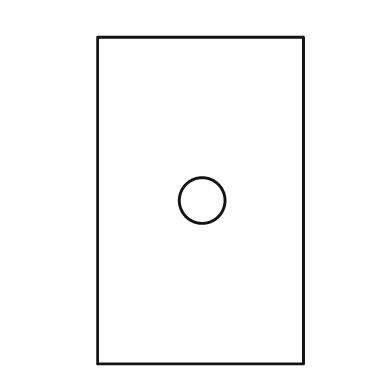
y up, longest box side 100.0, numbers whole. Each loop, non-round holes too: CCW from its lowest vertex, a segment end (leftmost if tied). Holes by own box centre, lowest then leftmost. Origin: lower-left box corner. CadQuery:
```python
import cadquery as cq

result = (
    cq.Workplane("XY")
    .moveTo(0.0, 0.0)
    .lineTo(63.0, 0.0)
    .lineTo(63.0, 100.0)
    .lineTo(0.0, 100.0)
    .close()
    .moveTo(32.0, 50.0)
    .circle(7.0)
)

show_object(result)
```